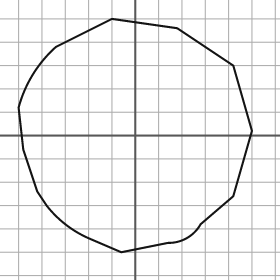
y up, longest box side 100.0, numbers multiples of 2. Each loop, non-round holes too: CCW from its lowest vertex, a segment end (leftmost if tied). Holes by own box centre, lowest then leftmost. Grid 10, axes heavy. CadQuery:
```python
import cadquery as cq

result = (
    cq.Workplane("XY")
    .moveTo(-6.0, -50.0)
    .lineTo(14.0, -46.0)
    .threePointArc((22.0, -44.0), (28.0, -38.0))
    .lineTo(42.0, -26.0)
    .lineTo(50.0, 2.0)
    .lineTo(42.0, 30.0)
    .lineTo(18.0, 46.0)
    .lineTo(-10.0, 50.0)
    .lineTo(-34.0, 38.0)
    .threePointArc((-44.0, 26.0), (-50.0, 12.0))
    .lineTo(-48.0, -6.0)
    .lineTo(-42.0, -24.0)
    .lineTo(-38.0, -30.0)
    .threePointArc((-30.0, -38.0), (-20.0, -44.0))
    .close()
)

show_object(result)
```